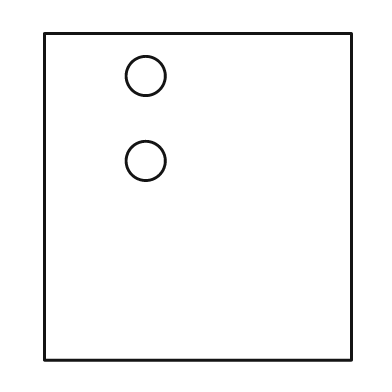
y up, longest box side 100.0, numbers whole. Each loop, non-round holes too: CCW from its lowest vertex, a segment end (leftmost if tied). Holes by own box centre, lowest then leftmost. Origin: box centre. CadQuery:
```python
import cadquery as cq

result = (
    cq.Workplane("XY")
    .moveTo(-47.0, -50.0)
    .lineTo(47.0, -50.0)
    .lineTo(47.0, 50.0)
    .lineTo(-47.0, 50.0)
    .close()
    .moveTo(-16.0, 11.0)
    .circle(6.0)
    .moveTo(-16.0, 37.0)
    .circle(6.0)
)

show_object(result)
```